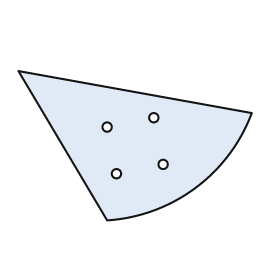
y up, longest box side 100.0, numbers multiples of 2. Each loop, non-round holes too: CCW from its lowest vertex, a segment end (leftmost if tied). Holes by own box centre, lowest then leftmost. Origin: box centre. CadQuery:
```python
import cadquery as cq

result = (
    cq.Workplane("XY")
    .moveTo(-12.0, -32.0)
    .threePointArc((26.0, -18.0), (50.0, 14.0))
    .lineTo(-50.0, 32.0)
    .close()
    .moveTo(-8.0, -12.0)
    .circle(2.0)
    .moveTo(12.0, -8.0)
    .circle(2.0)
    .moveTo(-12.0, 8.0)
    .circle(2.0)
    .moveTo(8.0, 12.0)
    .circle(2.0)
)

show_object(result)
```